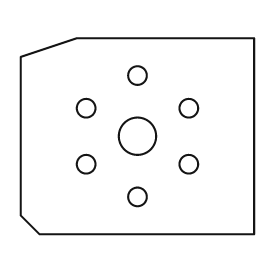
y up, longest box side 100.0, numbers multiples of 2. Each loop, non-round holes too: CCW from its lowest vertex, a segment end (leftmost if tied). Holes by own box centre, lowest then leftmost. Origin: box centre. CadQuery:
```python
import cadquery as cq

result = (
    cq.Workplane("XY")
    .moveTo(-42.0, -42.0)
    .lineTo(50.0, -42.0)
    .lineTo(50.0, 42.0)
    .lineTo(-26.0, 42.0)
    .lineTo(-50.0, 34.0)
    .lineTo(-50.0, -34.0)
    .close()
    .moveTo(0.0, -26.0)
    .circle(4.0)
    .moveTo(-22.0, -12.0)
    .circle(4.0)
    .moveTo(22.0, -12.0)
    .circle(4.0)
    .moveTo(0.0, 0.0)
    .circle(8.0)
    .moveTo(-22.0, 12.0)
    .circle(4.0)
    .moveTo(22.0, 12.0)
    .circle(4.0)
    .moveTo(0.0, 26.0)
    .circle(4.0)
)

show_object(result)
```